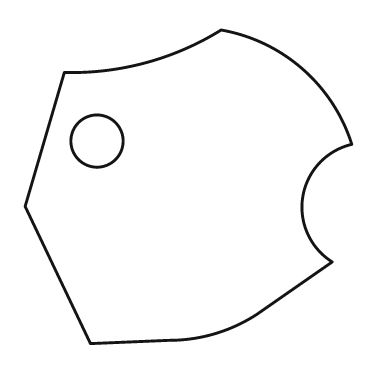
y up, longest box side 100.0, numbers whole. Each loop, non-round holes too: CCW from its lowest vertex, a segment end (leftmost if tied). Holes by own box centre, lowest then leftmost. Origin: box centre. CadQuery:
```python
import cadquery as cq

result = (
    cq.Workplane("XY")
    .moveTo(-30.0, -48.0)
    .lineTo(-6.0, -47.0)
    .threePointArc((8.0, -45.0), (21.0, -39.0))
    .lineTo(44.0, -23.0)
    .threePointArc((35.0, -3.0), (50.0, 13.0))
    .threePointArc((35.0, 36.0), (10.0, 48.0))
    .threePointArc((-13.0, 38.0), (-38.0, 35.0))
    .lineTo(-50.0, -6.0)
    .close()
    .moveTo(-28.0, 14.0)
    .circle(8.0)
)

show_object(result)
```